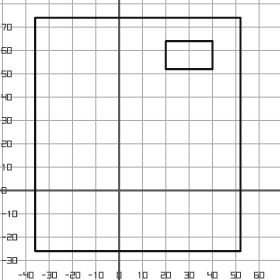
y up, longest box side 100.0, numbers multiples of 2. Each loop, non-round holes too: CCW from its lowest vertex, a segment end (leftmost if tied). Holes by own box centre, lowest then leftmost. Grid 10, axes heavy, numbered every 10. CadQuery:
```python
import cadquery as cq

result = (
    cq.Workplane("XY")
    .moveTo(-36.0, -26.0)
    .lineTo(52.0, -26.0)
    .lineTo(52.0, 74.0)
    .lineTo(-36.0, 74.0)
    .close()
    .moveTo(20.0, 52.0)
    .lineTo(40.0, 52.0)
    .lineTo(40.0, 64.0)
    .lineTo(20.0, 64.0)
    .close()
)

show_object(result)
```